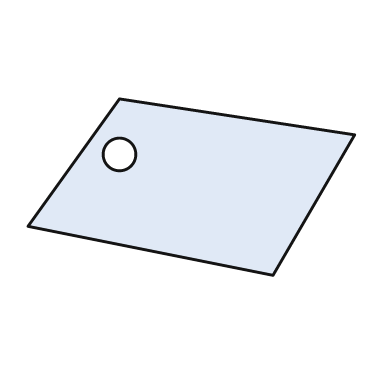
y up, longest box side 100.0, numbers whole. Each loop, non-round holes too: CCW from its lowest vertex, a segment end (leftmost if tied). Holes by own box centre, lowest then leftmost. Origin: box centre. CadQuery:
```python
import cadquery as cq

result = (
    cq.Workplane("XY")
    .moveTo(25.0, -27.0)
    .lineTo(50.0, 16.0)
    .lineTo(-22.0, 27.0)
    .lineTo(-50.0, -12.0)
    .close()
    .moveTo(-22.0, 10.0)
    .circle(5.0)
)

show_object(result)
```